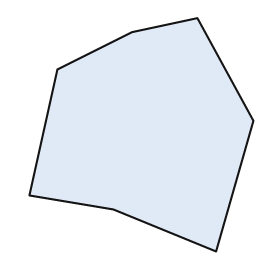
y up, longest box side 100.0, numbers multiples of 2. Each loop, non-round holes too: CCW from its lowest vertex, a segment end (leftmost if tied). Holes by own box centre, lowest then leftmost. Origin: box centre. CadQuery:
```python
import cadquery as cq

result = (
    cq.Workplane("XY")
    .moveTo(32.0, -50.0)
    .lineTo(48.0, 6.0)
    .lineTo(24.0, 50.0)
    .lineTo(-4.0, 44.0)
    .lineTo(-36.0, 28.0)
    .lineTo(-48.0, -26.0)
    .lineTo(-12.0, -32.0)
    .close()
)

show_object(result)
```